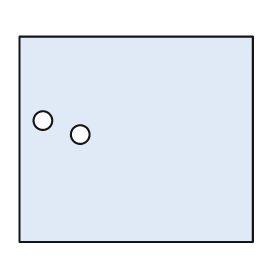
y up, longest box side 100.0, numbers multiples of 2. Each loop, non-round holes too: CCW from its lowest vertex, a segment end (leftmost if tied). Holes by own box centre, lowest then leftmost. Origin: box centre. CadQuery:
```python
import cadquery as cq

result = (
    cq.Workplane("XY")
    .moveTo(-50.0, -44.0)
    .lineTo(50.0, -44.0)
    .lineTo(50.0, 44.0)
    .lineTo(-50.0, 44.0)
    .close()
    .moveTo(-24.0, 2.0)
    .circle(4.0)
    .moveTo(-40.0, 8.0)
    .circle(4.0)
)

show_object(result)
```